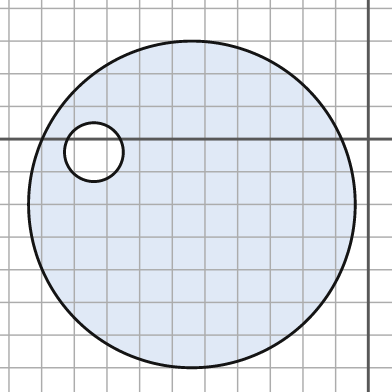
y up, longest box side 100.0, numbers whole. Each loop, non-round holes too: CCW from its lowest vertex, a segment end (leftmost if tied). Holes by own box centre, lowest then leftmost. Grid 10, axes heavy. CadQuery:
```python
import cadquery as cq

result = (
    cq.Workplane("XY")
    .moveTo(-54.0, -20.0)
    .circle(50.0)
    .moveTo(-84.0, -4.0)
    .circle(9.0)
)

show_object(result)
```